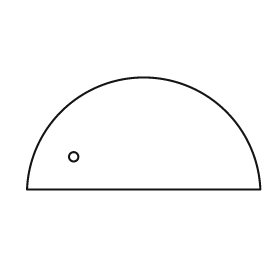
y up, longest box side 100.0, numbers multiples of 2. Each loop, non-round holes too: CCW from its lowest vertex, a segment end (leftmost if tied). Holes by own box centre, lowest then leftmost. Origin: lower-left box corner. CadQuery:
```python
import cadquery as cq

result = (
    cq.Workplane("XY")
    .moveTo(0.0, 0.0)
    .lineTo(100.0, 0.0)
    .threePointArc((50.0, 48.0), (0.0, 0.0))
    .close()
    .moveTo(20.0, 14.0)
    .circle(2.0)
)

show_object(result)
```